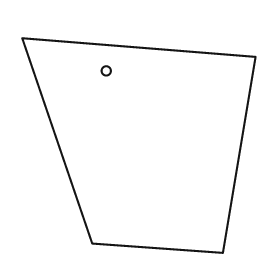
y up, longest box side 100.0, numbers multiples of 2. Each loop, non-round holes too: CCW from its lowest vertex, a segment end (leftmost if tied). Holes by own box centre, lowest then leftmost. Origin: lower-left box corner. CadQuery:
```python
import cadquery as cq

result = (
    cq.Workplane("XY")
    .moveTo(86.0, 0.0)
    .lineTo(100.0, 84.0)
    .lineTo(0.0, 92.0)
    .lineTo(30.0, 4.0)
    .close()
    .moveTo(36.0, 78.0)
    .circle(2.0)
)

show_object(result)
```